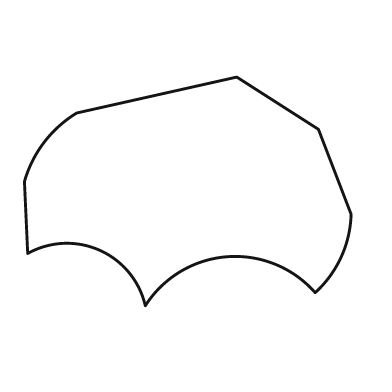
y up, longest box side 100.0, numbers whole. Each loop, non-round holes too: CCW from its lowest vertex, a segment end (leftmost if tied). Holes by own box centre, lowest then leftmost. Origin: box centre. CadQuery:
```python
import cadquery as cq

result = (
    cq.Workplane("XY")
    .moveTo(-13.0, -35.0)
    .threePointArc((12.0, -20.0), (39.0, -31.0))
    .threePointArc((47.0, -20.0), (50.0, -7.0))
    .lineTo(40.0, 19.0)
    .lineTo(15.0, 35.0)
    .lineTo(-34.0, 24.0)
    .threePointArc((-44.0, 15.0), (-50.0, 3.0))
    .lineTo(-49.0, -19.0)
    .threePointArc((-27.0, -18.0), (-13.0, -35.0))
    .close()
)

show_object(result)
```